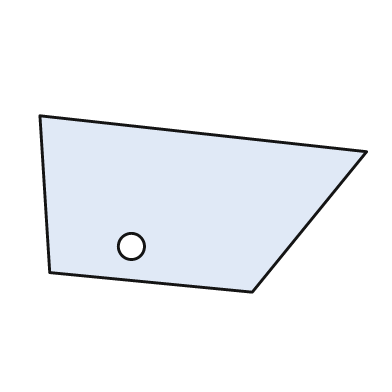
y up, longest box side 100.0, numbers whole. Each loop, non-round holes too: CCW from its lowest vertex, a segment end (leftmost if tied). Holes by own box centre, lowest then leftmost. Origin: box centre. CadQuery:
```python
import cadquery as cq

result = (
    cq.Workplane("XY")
    .moveTo(15.0, -27.0)
    .lineTo(50.0, 16.0)
    .lineTo(-50.0, 27.0)
    .lineTo(-47.0, -21.0)
    .close()
    .moveTo(-22.0, -13.0)
    .circle(4.0)
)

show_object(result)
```